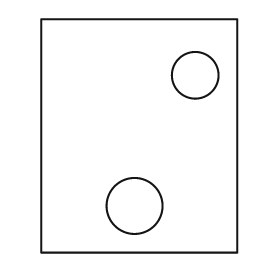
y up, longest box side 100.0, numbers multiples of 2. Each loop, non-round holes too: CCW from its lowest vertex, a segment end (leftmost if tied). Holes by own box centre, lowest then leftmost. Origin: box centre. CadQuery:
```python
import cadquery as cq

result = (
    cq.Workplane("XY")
    .moveTo(-42.0, -50.0)
    .lineTo(42.0, -50.0)
    .lineTo(42.0, 50.0)
    .lineTo(-42.0, 50.0)
    .close()
    .moveTo(-2.0, -30.0)
    .circle(12.0)
    .moveTo(24.0, 26.0)
    .circle(10.0)
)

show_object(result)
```